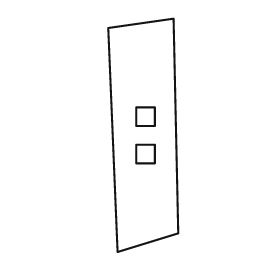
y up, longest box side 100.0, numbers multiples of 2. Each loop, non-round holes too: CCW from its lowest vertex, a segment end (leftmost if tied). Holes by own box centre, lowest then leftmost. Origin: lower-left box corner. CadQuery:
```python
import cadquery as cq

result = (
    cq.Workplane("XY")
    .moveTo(4.0, 0.0)
    .lineTo(30.0, 8.0)
    .lineTo(28.0, 100.0)
    .lineTo(0.0, 96.0)
    .close()
    .moveTo(12.0, 38.0)
    .lineTo(20.0, 38.0)
    .lineTo(20.0, 46.0)
    .lineTo(12.0, 46.0)
    .close()
    .moveTo(12.0, 54.0)
    .lineTo(20.0, 54.0)
    .lineTo(20.0, 62.0)
    .lineTo(12.0, 62.0)
    .close()
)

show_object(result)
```